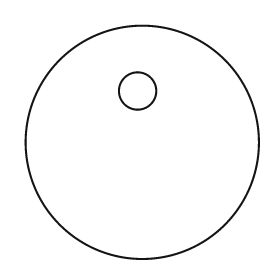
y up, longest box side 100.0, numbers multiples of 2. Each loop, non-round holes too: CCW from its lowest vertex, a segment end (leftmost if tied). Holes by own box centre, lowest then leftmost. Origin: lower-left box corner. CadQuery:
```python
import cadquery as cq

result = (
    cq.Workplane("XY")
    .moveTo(50.0, 50.0)
    .circle(50.0)
    .moveTo(48.0, 72.0)
    .circle(8.0)
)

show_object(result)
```